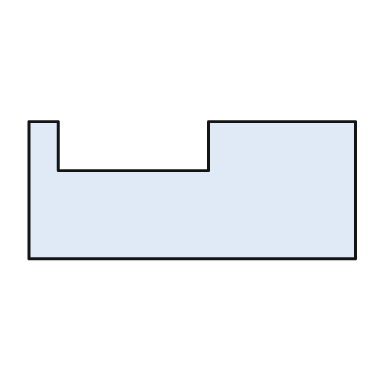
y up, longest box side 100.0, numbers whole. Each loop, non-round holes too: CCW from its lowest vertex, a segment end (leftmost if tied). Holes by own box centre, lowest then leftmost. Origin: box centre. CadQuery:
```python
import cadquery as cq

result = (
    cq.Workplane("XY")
    .moveTo(-50.0, -21.0)
    .lineTo(50.0, -21.0)
    .lineTo(50.0, 21.0)
    .lineTo(5.0, 21.0)
    .lineTo(5.0, 6.0)
    .lineTo(-41.0, 6.0)
    .lineTo(-41.0, 21.0)
    .lineTo(-50.0, 21.0)
    .close()
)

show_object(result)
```